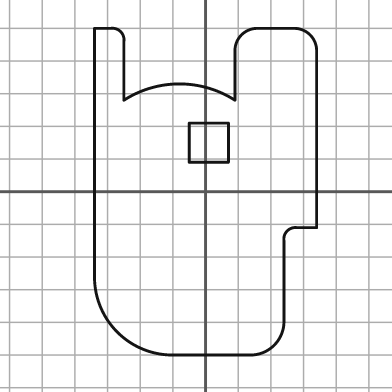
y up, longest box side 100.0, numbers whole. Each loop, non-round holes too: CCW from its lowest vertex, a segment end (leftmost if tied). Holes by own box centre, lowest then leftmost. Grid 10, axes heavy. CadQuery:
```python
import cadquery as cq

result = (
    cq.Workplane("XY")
    .moveTo(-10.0, -50.0)
    .lineTo(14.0, -50.0)
    .threePointArc((21.0, -47.0), (24.0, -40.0))
    .lineTo(24.0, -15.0)
    .threePointArc((25.0, -12.0), (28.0, -11.0))
    .lineTo(34.0, -11.0)
    .lineTo(34.0, 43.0)
    .threePointArc((32.0, 48.0), (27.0, 50.0))
    .lineTo(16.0, 50.0)
    .threePointArc((11.0, 48.0), (9.0, 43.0))
    .lineTo(9.0, 28.0)
    .threePointArc((-8.0, 33.0), (-25.0, 28.0))
    .lineTo(-25.0, 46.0)
    .threePointArc((-26.0, 49.0), (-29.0, 50.0))
    .lineTo(-34.0, 50.0)
    .lineTo(-34.0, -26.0)
    .threePointArc((-27.0, -43.0), (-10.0, -50.0))
    .close()
    .moveTo(-5.0, 9.0)
    .lineTo(7.0, 9.0)
    .lineTo(7.0, 21.0)
    .lineTo(-5.0, 21.0)
    .close()
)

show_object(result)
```